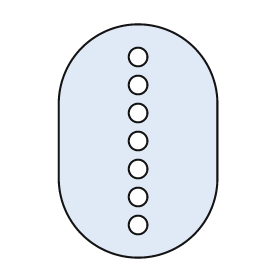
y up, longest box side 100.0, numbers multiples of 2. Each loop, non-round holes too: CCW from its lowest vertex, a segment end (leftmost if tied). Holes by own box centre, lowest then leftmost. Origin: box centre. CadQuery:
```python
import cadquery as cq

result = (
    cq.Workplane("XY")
    .moveTo(-34.0, -16.0)
    .threePointArc((0.0, -50.0), (34.0, -16.0))
    .lineTo(34.0, 16.0)
    .threePointArc((0.0, 50.0), (-34.0, 16.0))
    .close()
    .moveTo(0.0, -36.0)
    .circle(4.0)
    .moveTo(0.0, -24.0)
    .circle(4.0)
    .moveTo(0.0, -12.0)
    .circle(4.0)
    .moveTo(0.0, 0.0)
    .circle(4.0)
    .moveTo(0.0, 12.0)
    .circle(4.0)
    .moveTo(0.0, 24.0)
    .circle(4.0)
    .moveTo(0.0, 36.0)
    .circle(4.0)
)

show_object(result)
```